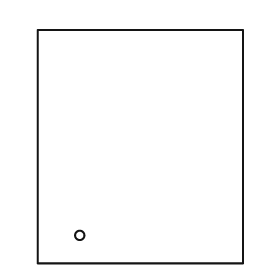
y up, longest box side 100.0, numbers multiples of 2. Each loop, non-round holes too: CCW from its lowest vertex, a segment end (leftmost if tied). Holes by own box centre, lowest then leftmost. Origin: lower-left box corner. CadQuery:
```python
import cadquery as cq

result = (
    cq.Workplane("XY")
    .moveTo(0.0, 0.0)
    .lineTo(88.0, 0.0)
    .lineTo(88.0, 100.0)
    .lineTo(0.0, 100.0)
    .close()
    .moveTo(18.0, 12.0)
    .circle(2.0)
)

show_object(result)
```